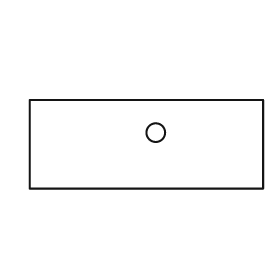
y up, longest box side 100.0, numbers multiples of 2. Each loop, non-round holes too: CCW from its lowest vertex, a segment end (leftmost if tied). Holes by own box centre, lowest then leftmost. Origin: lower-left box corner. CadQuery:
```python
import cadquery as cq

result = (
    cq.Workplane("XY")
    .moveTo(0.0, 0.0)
    .lineTo(100.0, 0.0)
    .lineTo(100.0, 38.0)
    .lineTo(0.0, 38.0)
    .close()
    .moveTo(54.0, 24.0)
    .circle(4.0)
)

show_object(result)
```